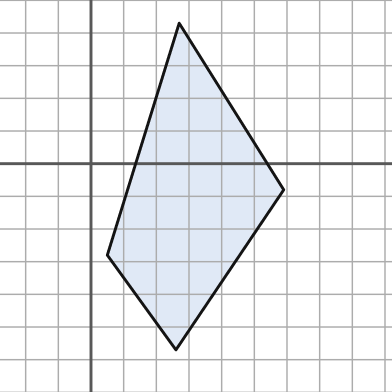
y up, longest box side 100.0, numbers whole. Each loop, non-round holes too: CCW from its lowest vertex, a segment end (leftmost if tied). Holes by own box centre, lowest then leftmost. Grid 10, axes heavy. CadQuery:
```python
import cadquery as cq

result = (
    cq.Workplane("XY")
    .moveTo(26.0, -57.0)
    .lineTo(59.0, -8.0)
    .lineTo(27.0, 43.0)
    .lineTo(5.0, -28.0)
    .close()
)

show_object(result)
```